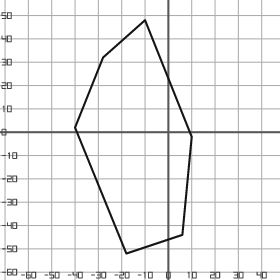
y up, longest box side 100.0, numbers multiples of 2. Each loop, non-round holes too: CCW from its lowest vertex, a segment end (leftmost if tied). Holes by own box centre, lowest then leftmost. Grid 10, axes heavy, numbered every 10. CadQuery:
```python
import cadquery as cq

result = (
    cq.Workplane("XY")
    .moveTo(-18.0, -52.0)
    .lineTo(6.0, -44.0)
    .lineTo(10.0, -2.0)
    .lineTo(-10.0, 48.0)
    .lineTo(-28.0, 32.0)
    .lineTo(-40.0, 2.0)
    .close()
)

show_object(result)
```